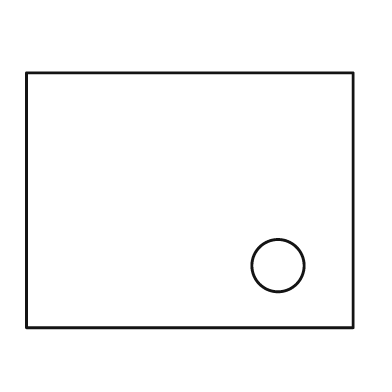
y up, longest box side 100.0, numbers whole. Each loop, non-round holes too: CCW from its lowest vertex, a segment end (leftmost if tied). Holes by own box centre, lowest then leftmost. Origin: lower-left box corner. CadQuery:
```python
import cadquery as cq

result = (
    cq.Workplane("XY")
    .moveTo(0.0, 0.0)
    .lineTo(100.0, 0.0)
    .lineTo(100.0, 78.0)
    .lineTo(0.0, 78.0)
    .close()
    .moveTo(77.0, 19.0)
    .circle(8.0)
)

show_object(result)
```